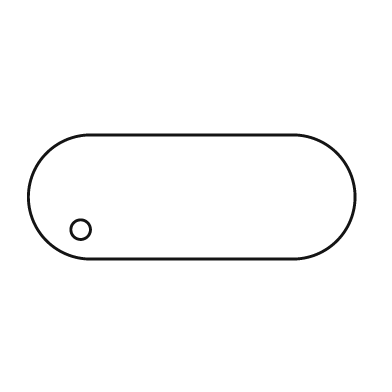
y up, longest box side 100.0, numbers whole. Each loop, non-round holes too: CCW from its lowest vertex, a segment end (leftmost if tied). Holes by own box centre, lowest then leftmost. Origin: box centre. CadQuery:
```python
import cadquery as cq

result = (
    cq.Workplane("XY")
    .moveTo(-31.0, -19.0)
    .lineTo(31.0, -19.0)
    .threePointArc((50.0, 0.0), (31.0, 19.0))
    .lineTo(-31.0, 19.0)
    .threePointArc((-50.0, 0.0), (-31.0, -19.0))
    .close()
    .moveTo(-34.0, -10.0)
    .circle(3.0)
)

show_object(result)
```